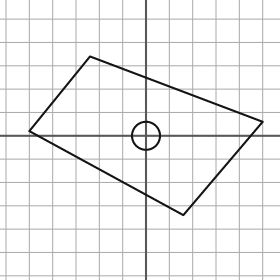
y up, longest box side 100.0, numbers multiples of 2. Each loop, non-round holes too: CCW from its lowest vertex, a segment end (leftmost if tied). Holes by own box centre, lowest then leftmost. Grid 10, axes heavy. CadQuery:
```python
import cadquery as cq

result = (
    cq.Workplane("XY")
    .moveTo(16.0, -34.0)
    .lineTo(50.0, 6.0)
    .lineTo(-24.0, 34.0)
    .lineTo(-50.0, 2.0)
    .close()
    .moveTo(0.0, 0.0)
    .circle(6.0)
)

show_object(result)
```